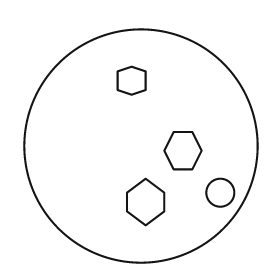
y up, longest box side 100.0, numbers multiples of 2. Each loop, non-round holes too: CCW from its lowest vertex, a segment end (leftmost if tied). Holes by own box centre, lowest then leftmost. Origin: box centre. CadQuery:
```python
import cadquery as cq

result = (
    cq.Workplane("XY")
    .moveTo(0.0, 0.0)
    .circle(50.0)
    .moveTo(2.0, -34.0)
    .lineTo(10.0, -28.0)
    .lineTo(10.0, -20.0)
    .lineTo(2.0, -14.0)
    .lineTo(-6.0, -20.0)
    .lineTo(-6.0, -28.0)
    .close()
    .moveTo(34.0, -20.0)
    .circle(6.0)
    .moveTo(14.0, -10.0)
    .lineTo(22.0, -10.0)
    .lineTo(26.0, -2.0)
    .lineTo(22.0, 6.0)
    .lineTo(14.0, 6.0)
    .lineTo(10.0, -2.0)
    .close()
    .moveTo(-4.0, 22.0)
    .lineTo(2.0, 24.0)
    .lineTo(2.0, 32.0)
    .lineTo(-4.0, 34.0)
    .lineTo(-10.0, 32.0)
    .lineTo(-10.0, 24.0)
    .close()
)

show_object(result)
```